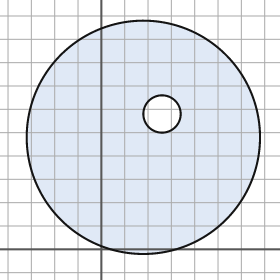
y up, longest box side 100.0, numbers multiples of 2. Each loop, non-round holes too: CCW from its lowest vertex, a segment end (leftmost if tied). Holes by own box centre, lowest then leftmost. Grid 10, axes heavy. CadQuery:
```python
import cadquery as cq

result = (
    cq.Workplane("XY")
    .moveTo(18.0, 48.0)
    .circle(50.0)
    .moveTo(26.0, 58.0)
    .circle(8.0)
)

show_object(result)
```